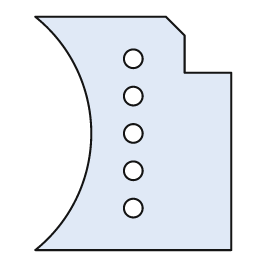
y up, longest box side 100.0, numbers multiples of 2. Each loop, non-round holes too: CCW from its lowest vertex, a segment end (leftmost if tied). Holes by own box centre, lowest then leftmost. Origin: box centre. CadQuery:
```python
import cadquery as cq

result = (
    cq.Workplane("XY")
    .moveTo(-42.0, -50.0)
    .lineTo(42.0, -50.0)
    .lineTo(42.0, 26.0)
    .lineTo(22.0, 26.0)
    .lineTo(22.0, 42.0)
    .lineTo(14.0, 50.0)
    .lineTo(-42.0, 50.0)
    .threePointArc((-18.0, 0.0), (-42.0, -50.0))
    .close()
    .moveTo(0.0, -32.0)
    .circle(4.0)
    .moveTo(0.0, -16.0)
    .circle(4.0)
    .moveTo(0.0, 0.0)
    .circle(4.0)
    .moveTo(0.0, 16.0)
    .circle(4.0)
    .moveTo(0.0, 32.0)
    .circle(4.0)
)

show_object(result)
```